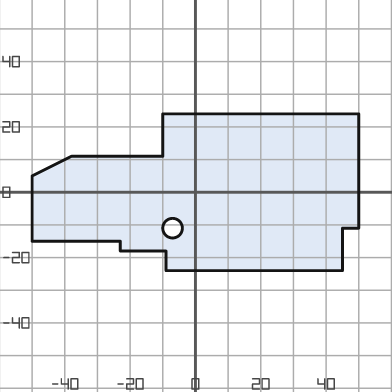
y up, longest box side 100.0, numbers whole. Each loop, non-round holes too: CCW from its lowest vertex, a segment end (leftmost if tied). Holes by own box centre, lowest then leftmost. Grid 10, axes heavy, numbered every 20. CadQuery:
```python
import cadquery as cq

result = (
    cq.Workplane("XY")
    .moveTo(-9.0, -24.0)
    .lineTo(45.0, -24.0)
    .lineTo(45.0, -11.0)
    .lineTo(50.0, -11.0)
    .lineTo(50.0, 24.0)
    .lineTo(-10.0, 24.0)
    .lineTo(-10.0, 11.0)
    .lineTo(-38.0, 11.0)
    .lineTo(-50.0, 5.0)
    .lineTo(-50.0, -15.0)
    .lineTo(-23.0, -15.0)
    .lineTo(-23.0, -18.0)
    .lineTo(-9.0, -18.0)
    .close()
    .moveTo(-7.0, -11.0)
    .circle(3.0)
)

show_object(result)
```